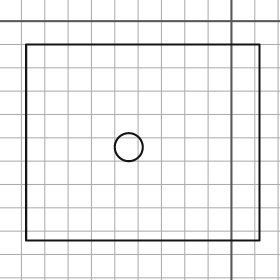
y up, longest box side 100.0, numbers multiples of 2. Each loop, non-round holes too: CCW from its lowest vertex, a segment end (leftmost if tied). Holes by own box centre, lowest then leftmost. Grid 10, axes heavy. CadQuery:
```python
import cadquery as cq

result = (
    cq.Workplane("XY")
    .moveTo(-88.0, -94.0)
    .lineTo(12.0, -94.0)
    .lineTo(12.0, -10.0)
    .lineTo(-88.0, -10.0)
    .close()
    .moveTo(-44.0, -54.0)
    .circle(6.0)
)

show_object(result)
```